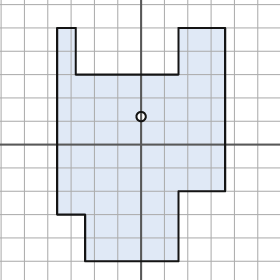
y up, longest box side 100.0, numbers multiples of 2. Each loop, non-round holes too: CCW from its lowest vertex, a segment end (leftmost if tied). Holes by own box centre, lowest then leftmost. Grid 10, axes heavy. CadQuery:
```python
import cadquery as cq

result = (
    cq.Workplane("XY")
    .moveTo(-24.0, -50.0)
    .lineTo(16.0, -50.0)
    .lineTo(16.0, -20.0)
    .lineTo(36.0, -20.0)
    .lineTo(36.0, 50.0)
    .lineTo(16.0, 50.0)
    .lineTo(16.0, 30.0)
    .lineTo(-28.0, 30.0)
    .lineTo(-28.0, 50.0)
    .lineTo(-36.0, 50.0)
    .lineTo(-36.0, -30.0)
    .lineTo(-24.0, -30.0)
    .close()
    .moveTo(0.0, 12.0)
    .circle(2.0)
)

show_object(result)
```